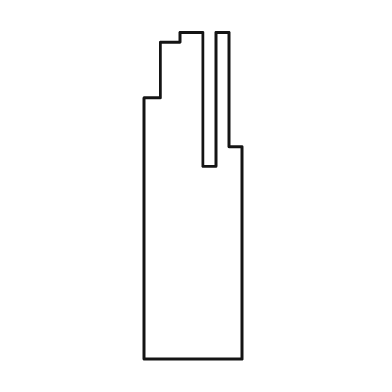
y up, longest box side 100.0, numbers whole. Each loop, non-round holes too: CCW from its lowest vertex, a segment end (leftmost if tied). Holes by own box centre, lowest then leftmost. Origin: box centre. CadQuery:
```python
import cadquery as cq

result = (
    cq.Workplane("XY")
    .moveTo(-15.0, -50.0)
    .lineTo(15.0, -50.0)
    .lineTo(15.0, 15.0)
    .lineTo(11.0, 15.0)
    .lineTo(11.0, 50.0)
    .lineTo(7.0, 50.0)
    .lineTo(7.0, 9.0)
    .lineTo(3.0, 9.0)
    .lineTo(3.0, 50.0)
    .lineTo(-4.0, 50.0)
    .lineTo(-4.0, 47.0)
    .lineTo(-10.0, 47.0)
    .lineTo(-10.0, 30.0)
    .lineTo(-15.0, 30.0)
    .close()
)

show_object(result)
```